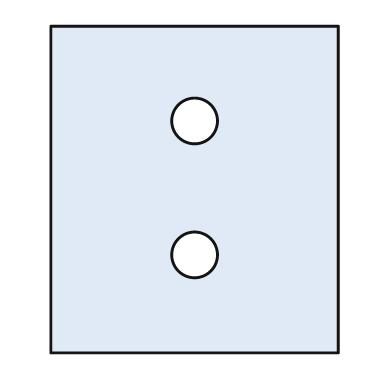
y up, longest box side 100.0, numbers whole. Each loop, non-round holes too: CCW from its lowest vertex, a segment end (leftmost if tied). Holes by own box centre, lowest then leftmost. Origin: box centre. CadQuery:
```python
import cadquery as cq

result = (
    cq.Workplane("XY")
    .moveTo(-44.0, -50.0)
    .lineTo(44.0, -50.0)
    .lineTo(44.0, 50.0)
    .lineTo(-44.0, 50.0)
    .close()
    .moveTo(0.0, -20.0)
    .circle(7.0)
    .moveTo(0.0, 21.0)
    .circle(7.0)
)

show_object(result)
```